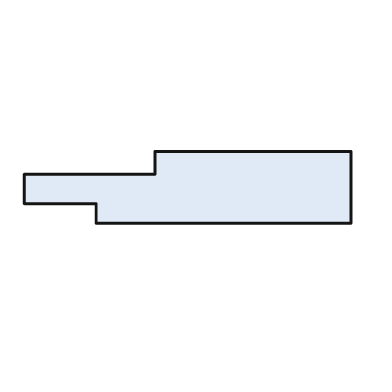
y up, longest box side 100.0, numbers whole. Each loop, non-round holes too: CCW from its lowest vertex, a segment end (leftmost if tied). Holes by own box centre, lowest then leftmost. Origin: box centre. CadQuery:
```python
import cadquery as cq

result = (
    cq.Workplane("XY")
    .moveTo(-28.0, -11.0)
    .lineTo(50.0, -11.0)
    .lineTo(50.0, 11.0)
    .lineTo(-10.0, 11.0)
    .lineTo(-10.0, 4.0)
    .lineTo(-50.0, 4.0)
    .lineTo(-50.0, -5.0)
    .lineTo(-28.0, -5.0)
    .close()
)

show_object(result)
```